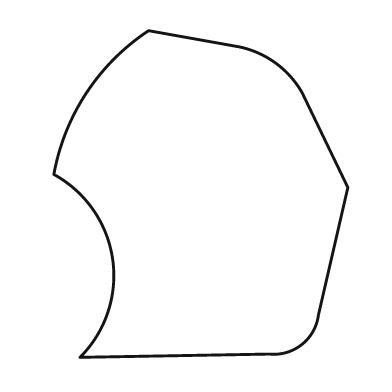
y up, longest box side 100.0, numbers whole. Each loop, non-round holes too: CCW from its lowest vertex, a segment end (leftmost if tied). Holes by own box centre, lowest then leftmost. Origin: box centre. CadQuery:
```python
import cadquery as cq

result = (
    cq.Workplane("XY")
    .moveTo(-37.0, -50.0)
    .lineTo(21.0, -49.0)
    .threePointArc((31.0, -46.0), (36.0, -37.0))
    .lineTo(45.0, 2.0)
    .lineTo(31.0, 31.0)
    .threePointArc((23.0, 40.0), (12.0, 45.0))
    .lineTo(-16.0, 50.0)
    .threePointArc((-35.0, 31.0), (-45.0, 6.0))
    .threePointArc((-27.0, -20.0), (-37.0, -50.0))
    .close()
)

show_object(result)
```